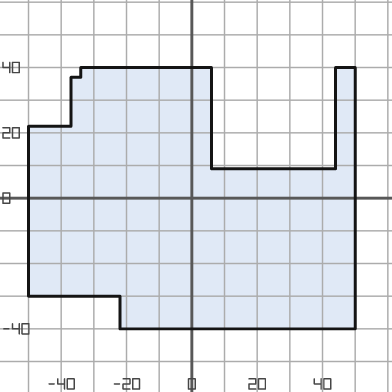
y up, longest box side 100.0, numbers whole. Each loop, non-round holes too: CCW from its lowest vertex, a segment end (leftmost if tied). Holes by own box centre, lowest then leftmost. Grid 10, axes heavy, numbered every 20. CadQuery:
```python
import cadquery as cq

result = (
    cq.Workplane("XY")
    .moveTo(-22.0, -40.0)
    .lineTo(50.0, -40.0)
    .lineTo(50.0, 40.0)
    .lineTo(44.0, 40.0)
    .lineTo(44.0, 9.0)
    .lineTo(6.0, 9.0)
    .lineTo(6.0, 40.0)
    .lineTo(-34.0, 40.0)
    .lineTo(-34.0, 37.0)
    .lineTo(-37.0, 37.0)
    .lineTo(-37.0, 22.0)
    .lineTo(-50.0, 22.0)
    .lineTo(-50.0, -30.0)
    .lineTo(-22.0, -30.0)
    .close()
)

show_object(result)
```